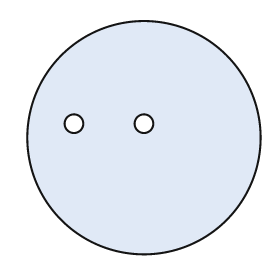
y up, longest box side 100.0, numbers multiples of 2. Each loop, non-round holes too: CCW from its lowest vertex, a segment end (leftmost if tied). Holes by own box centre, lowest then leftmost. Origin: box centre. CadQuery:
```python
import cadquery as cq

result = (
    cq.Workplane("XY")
    .moveTo(0.0, 0.0)
    .circle(50.0)
    .moveTo(-30.0, 6.0)
    .circle(4.0)
    .moveTo(0.0, 6.0)
    .circle(4.0)
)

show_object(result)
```